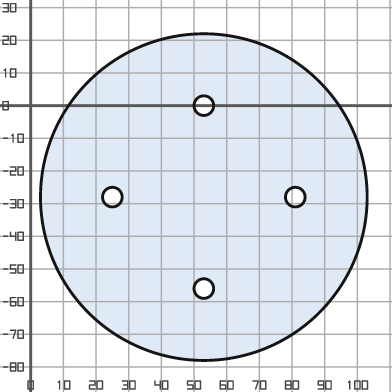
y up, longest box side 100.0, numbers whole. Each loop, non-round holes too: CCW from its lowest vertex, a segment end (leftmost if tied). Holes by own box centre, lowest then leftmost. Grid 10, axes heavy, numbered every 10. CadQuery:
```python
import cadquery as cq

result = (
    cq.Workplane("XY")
    .moveTo(53.0, -28.0)
    .circle(50.0)
    .moveTo(53.0, -56.0)
    .circle(3.0)
    .moveTo(25.0, -28.0)
    .circle(3.0)
    .moveTo(81.0, -28.0)
    .circle(3.0)
    .moveTo(53.0, 0.0)
    .circle(3.0)
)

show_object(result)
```